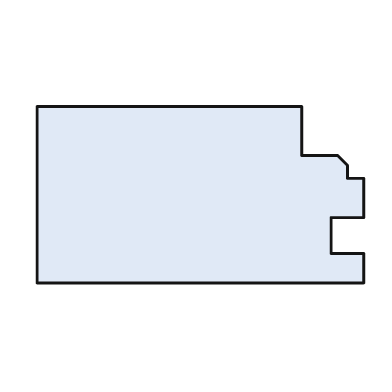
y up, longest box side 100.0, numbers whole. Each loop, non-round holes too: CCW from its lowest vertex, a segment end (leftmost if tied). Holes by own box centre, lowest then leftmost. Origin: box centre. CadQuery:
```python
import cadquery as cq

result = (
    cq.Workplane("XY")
    .moveTo(-50.0, -27.0)
    .lineTo(50.0, -27.0)
    .lineTo(50.0, -18.0)
    .lineTo(40.0, -18.0)
    .lineTo(40.0, -7.0)
    .lineTo(50.0, -7.0)
    .lineTo(50.0, 5.0)
    .lineTo(45.0, 5.0)
    .lineTo(45.0, 9.0)
    .lineTo(42.0, 12.0)
    .lineTo(31.0, 12.0)
    .lineTo(31.0, 27.0)
    .lineTo(-50.0, 27.0)
    .close()
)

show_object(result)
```